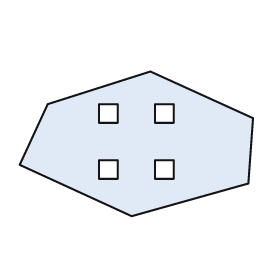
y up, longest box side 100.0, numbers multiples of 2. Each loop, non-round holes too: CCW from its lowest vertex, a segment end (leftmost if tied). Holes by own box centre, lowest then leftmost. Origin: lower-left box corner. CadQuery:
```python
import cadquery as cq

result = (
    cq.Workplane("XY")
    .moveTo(48.0, 0.0)
    .lineTo(98.0, 14.0)
    .lineTo(100.0, 42.0)
    .lineTo(56.0, 62.0)
    .lineTo(12.0, 48.0)
    .lineTo(0.0, 22.0)
    .close()
    .moveTo(34.0, 16.0)
    .lineTo(42.0, 16.0)
    .lineTo(42.0, 24.0)
    .lineTo(34.0, 24.0)
    .close()
    .moveTo(58.0, 16.0)
    .lineTo(66.0, 16.0)
    .lineTo(66.0, 24.0)
    .lineTo(58.0, 24.0)
    .close()
    .moveTo(34.0, 40.0)
    .lineTo(42.0, 40.0)
    .lineTo(42.0, 48.0)
    .lineTo(34.0, 48.0)
    .close()
    .moveTo(58.0, 40.0)
    .lineTo(66.0, 40.0)
    .lineTo(66.0, 48.0)
    .lineTo(58.0, 48.0)
    .close()
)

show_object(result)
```